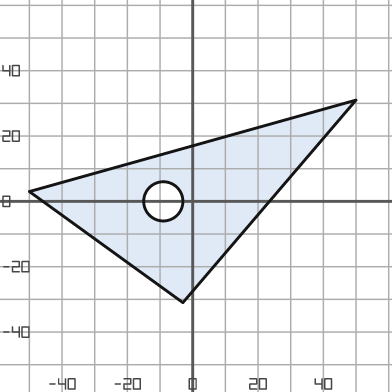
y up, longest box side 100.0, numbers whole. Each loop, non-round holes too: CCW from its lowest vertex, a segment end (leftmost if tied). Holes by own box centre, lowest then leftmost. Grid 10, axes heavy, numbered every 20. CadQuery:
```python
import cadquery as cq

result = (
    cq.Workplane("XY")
    .moveTo(-3.0, -31.0)
    .lineTo(50.0, 31.0)
    .lineTo(-50.0, 3.0)
    .close()
    .moveTo(-9.0, 0.0)
    .circle(6.0)
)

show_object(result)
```